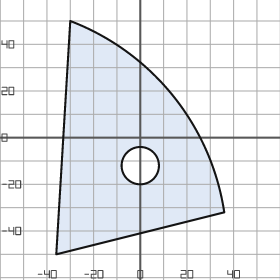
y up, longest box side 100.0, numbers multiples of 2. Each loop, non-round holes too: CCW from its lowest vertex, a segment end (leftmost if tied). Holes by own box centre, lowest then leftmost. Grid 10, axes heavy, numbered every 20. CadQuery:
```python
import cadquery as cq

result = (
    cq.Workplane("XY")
    .moveTo(-36.0, -50.0)
    .lineTo(36.0, -32.0)
    .threePointArc((14.0, 18.0), (-30.0, 50.0))
    .close()
    .moveTo(0.0, -12.0)
    .circle(8.0)
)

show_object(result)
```